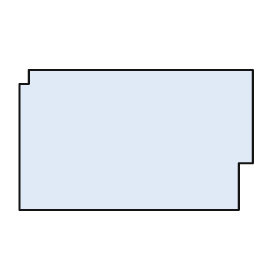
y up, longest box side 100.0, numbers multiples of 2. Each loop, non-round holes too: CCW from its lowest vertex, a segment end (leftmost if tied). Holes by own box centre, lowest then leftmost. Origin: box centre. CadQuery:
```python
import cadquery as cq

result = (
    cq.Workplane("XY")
    .moveTo(-50.0, -30.0)
    .lineTo(44.0, -30.0)
    .lineTo(44.0, -10.0)
    .lineTo(50.0, -10.0)
    .lineTo(50.0, 30.0)
    .lineTo(-46.0, 30.0)
    .lineTo(-46.0, 24.0)
    .lineTo(-50.0, 24.0)
    .close()
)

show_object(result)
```